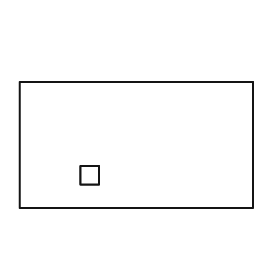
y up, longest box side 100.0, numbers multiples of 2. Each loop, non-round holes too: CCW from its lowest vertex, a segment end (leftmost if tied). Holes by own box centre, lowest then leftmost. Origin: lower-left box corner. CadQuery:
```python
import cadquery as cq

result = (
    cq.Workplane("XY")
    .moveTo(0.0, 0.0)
    .lineTo(100.0, 0.0)
    .lineTo(100.0, 54.0)
    .lineTo(0.0, 54.0)
    .close()
    .moveTo(26.0, 10.0)
    .lineTo(34.0, 10.0)
    .lineTo(34.0, 18.0)
    .lineTo(26.0, 18.0)
    .close()
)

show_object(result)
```